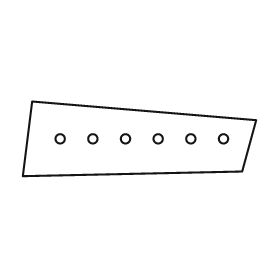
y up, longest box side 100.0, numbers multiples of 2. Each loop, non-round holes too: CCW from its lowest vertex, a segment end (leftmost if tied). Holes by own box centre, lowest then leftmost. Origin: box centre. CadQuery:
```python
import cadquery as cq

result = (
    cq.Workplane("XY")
    .moveTo(-50.0, -16.0)
    .lineTo(44.0, -14.0)
    .lineTo(50.0, 8.0)
    .lineTo(-46.0, 16.0)
    .close()
    .moveTo(-34.0, 0.0)
    .circle(2.0)
    .moveTo(-20.0, 0.0)
    .circle(2.0)
    .moveTo(-6.0, 0.0)
    .circle(2.0)
    .moveTo(8.0, 0.0)
    .circle(2.0)
    .moveTo(22.0, 0.0)
    .circle(2.0)
    .moveTo(36.0, 0.0)
    .circle(2.0)
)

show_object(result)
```